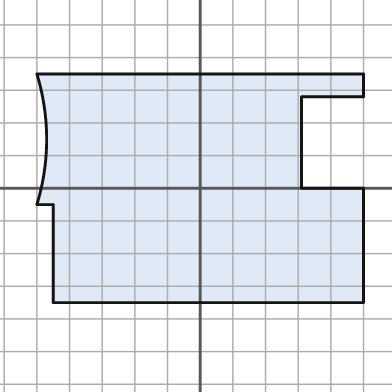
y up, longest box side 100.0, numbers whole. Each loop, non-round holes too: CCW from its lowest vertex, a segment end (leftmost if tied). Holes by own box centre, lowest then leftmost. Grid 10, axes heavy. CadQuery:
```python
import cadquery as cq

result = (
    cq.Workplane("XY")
    .moveTo(-45.0, -35.0)
    .lineTo(50.0, -35.0)
    .lineTo(50.0, 0.0)
    .lineTo(31.0, 0.0)
    .lineTo(31.0, 28.0)
    .lineTo(50.0, 28.0)
    .lineTo(50.0, 35.0)
    .lineTo(-50.0, 35.0)
    .threePointArc((-47.0, 15.0), (-50.0, -5.0))
    .lineTo(-45.0, -5.0)
    .close()
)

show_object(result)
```